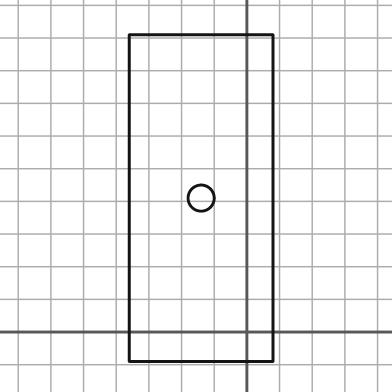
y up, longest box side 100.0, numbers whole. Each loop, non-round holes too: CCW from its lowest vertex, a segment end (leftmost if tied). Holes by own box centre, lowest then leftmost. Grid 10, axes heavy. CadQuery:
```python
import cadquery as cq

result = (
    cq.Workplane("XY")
    .moveTo(-36.0, -9.0)
    .lineTo(8.0, -9.0)
    .lineTo(8.0, 91.0)
    .lineTo(-36.0, 91.0)
    .close()
    .moveTo(-14.0, 41.0)
    .circle(4.0)
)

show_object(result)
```